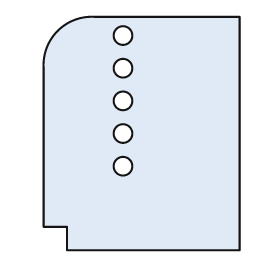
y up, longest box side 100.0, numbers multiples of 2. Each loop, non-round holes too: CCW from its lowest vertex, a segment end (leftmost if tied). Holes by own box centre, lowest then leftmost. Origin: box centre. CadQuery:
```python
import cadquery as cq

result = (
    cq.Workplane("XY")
    .moveTo(-32.0, -50.0)
    .lineTo(42.0, -50.0)
    .lineTo(42.0, 50.0)
    .lineTo(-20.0, 50.0)
    .threePointArc((-36.0, 44.0), (-42.0, 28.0))
    .lineTo(-42.0, -40.0)
    .lineTo(-32.0, -40.0)
    .close()
    .moveTo(-8.0, -14.0)
    .circle(4.0)
    .moveTo(-8.0, 0.0)
    .circle(4.0)
    .moveTo(-8.0, 14.0)
    .circle(4.0)
    .moveTo(-8.0, 28.0)
    .circle(4.0)
    .moveTo(-8.0, 42.0)
    .circle(4.0)
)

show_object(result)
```